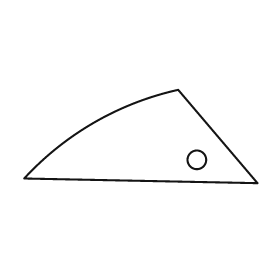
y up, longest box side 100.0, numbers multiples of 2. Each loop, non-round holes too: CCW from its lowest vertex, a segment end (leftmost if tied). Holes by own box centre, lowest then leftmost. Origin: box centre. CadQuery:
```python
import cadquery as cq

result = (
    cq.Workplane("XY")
    .moveTo(50.0, -20.0)
    .lineTo(16.0, 20.0)
    .threePointArc((-20.0, 6.0), (-50.0, -18.0))
    .close()
    .moveTo(24.0, -10.0)
    .circle(4.0)
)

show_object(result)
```